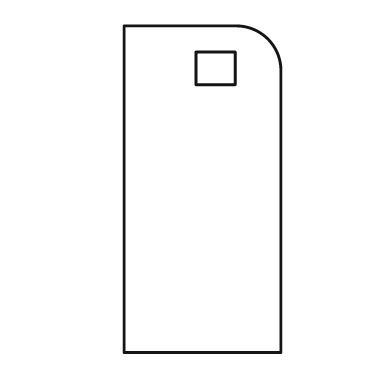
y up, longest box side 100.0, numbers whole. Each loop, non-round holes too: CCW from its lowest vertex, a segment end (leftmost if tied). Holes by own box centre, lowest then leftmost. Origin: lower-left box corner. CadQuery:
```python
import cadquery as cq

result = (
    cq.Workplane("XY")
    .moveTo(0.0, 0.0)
    .lineTo(48.0, 0.0)
    .lineTo(48.0, 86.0)
    .threePointArc((44.0, 96.0), (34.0, 100.0))
    .lineTo(0.0, 100.0)
    .close()
    .moveTo(22.0, 82.0)
    .lineTo(34.0, 82.0)
    .lineTo(34.0, 92.0)
    .lineTo(22.0, 92.0)
    .close()
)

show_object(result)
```